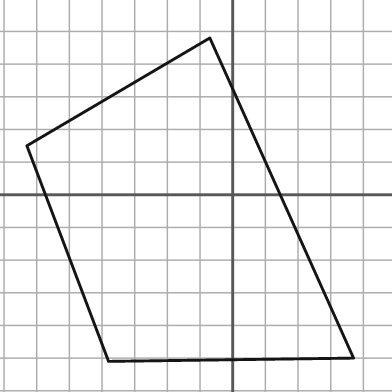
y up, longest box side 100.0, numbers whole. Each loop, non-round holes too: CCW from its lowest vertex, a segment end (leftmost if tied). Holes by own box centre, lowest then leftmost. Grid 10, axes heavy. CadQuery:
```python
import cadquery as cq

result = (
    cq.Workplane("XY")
    .moveTo(-38.0, -51.0)
    .lineTo(37.0, -50.0)
    .lineTo(-7.0, 48.0)
    .lineTo(-63.0, 15.0)
    .close()
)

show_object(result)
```